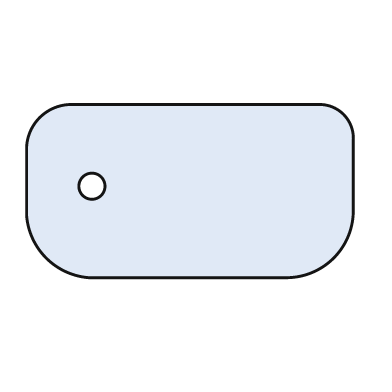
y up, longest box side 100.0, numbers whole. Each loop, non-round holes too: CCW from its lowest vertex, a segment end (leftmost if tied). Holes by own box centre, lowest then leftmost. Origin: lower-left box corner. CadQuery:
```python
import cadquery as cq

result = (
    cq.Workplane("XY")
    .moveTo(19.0, 0.0)
    .lineTo(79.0, 0.0)
    .threePointArc((94.0, 6.0), (100.0, 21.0))
    .lineTo(100.0, 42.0)
    .threePointArc((97.0, 50.0), (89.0, 53.0))
    .lineTo(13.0, 53.0)
    .threePointArc((4.0, 49.0), (0.0, 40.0))
    .lineTo(0.0, 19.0)
    .threePointArc((6.0, 6.0), (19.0, 0.0))
    .close()
    .moveTo(20.0, 28.0)
    .circle(4.0)
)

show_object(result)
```